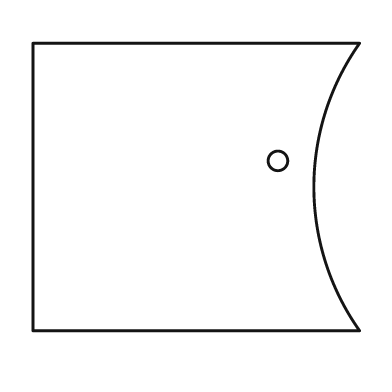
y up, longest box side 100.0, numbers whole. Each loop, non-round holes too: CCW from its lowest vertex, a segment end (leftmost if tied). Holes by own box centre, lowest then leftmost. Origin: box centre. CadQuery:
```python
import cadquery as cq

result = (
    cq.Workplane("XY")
    .moveTo(-50.0, -44.0)
    .lineTo(50.0, -44.0)
    .threePointArc((36.0, 0.0), (50.0, 44.0))
    .lineTo(-50.0, 44.0)
    .close()
    .moveTo(25.0, 8.0)
    .circle(3.0)
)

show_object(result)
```